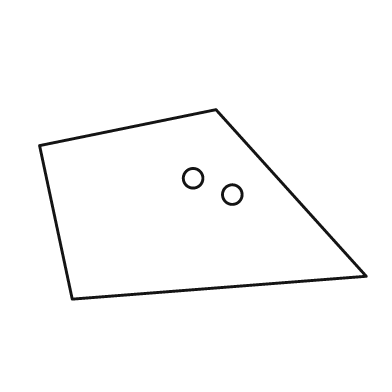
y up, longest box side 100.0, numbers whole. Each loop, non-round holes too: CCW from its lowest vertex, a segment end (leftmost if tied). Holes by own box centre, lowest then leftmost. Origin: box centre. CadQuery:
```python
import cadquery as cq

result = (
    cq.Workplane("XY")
    .moveTo(-40.0, -29.0)
    .lineTo(50.0, -22.0)
    .lineTo(4.0, 29.0)
    .lineTo(-50.0, 18.0)
    .close()
    .moveTo(9.0, 3.0)
    .circle(3.0)
    .moveTo(-3.0, 8.0)
    .circle(3.0)
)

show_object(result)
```